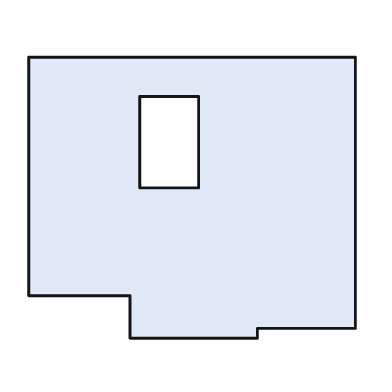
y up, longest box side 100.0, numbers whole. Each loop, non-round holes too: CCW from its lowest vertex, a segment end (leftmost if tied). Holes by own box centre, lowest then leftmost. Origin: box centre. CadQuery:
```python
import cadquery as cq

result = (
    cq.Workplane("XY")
    .moveTo(-19.0, -43.0)
    .lineTo(20.0, -43.0)
    .lineTo(20.0, -40.0)
    .lineTo(50.0, -40.0)
    .lineTo(50.0, 43.0)
    .lineTo(-50.0, 43.0)
    .lineTo(-50.0, -30.0)
    .lineTo(-19.0, -30.0)
    .close()
    .moveTo(-16.0, 3.0)
    .lineTo(2.0, 3.0)
    .lineTo(2.0, 31.0)
    .lineTo(-16.0, 31.0)
    .close()
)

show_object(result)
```